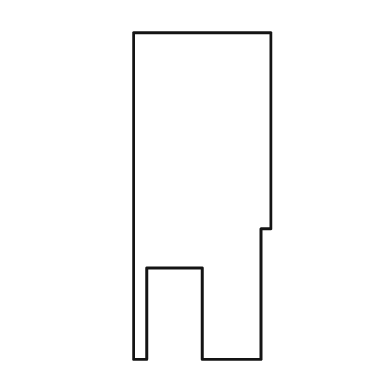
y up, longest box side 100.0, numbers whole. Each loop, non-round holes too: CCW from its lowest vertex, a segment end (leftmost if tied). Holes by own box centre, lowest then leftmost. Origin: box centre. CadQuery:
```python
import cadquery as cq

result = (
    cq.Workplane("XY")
    .moveTo(-21.0, -50.0)
    .lineTo(-17.0, -50.0)
    .lineTo(-17.0, -22.0)
    .lineTo(0.0, -22.0)
    .lineTo(0.0, -50.0)
    .lineTo(18.0, -50.0)
    .lineTo(18.0, -10.0)
    .lineTo(21.0, -10.0)
    .lineTo(21.0, 50.0)
    .lineTo(-21.0, 50.0)
    .close()
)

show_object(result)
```